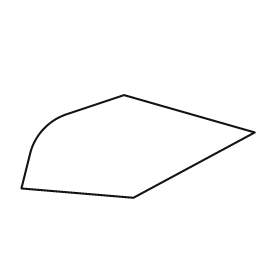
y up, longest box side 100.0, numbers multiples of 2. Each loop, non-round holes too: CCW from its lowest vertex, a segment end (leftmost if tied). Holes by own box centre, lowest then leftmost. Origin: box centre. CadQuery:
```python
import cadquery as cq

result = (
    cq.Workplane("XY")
    .moveTo(-2.0, -22.0)
    .lineTo(50.0, 6.0)
    .lineTo(-6.0, 22.0)
    .lineTo(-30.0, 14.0)
    .threePointArc((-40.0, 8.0), (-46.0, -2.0))
    .lineTo(-50.0, -18.0)
    .close()
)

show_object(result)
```